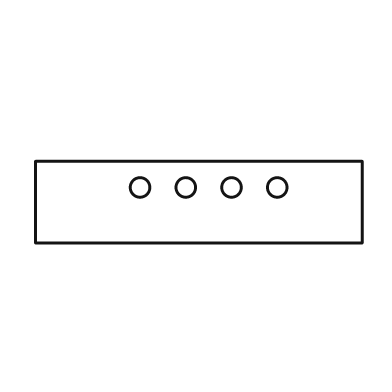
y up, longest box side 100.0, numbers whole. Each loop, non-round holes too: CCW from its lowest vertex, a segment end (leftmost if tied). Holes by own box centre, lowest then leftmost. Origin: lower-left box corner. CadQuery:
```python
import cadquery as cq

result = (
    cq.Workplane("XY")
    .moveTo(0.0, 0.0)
    .lineTo(100.0, 0.0)
    .lineTo(100.0, 25.0)
    .lineTo(0.0, 25.0)
    .close()
    .moveTo(32.0, 17.0)
    .circle(3.0)
    .moveTo(46.0, 17.0)
    .circle(3.0)
    .moveTo(60.0, 17.0)
    .circle(3.0)
    .moveTo(74.0, 17.0)
    .circle(3.0)
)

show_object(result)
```